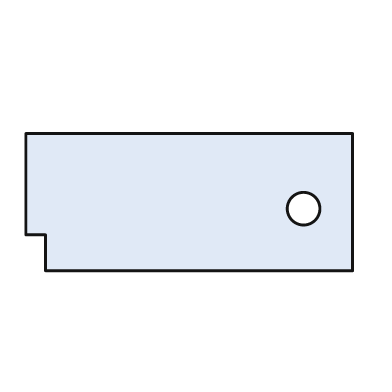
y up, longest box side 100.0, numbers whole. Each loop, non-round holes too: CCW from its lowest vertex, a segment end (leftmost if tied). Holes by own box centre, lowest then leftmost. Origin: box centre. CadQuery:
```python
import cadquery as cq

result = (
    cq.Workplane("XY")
    .moveTo(-44.0, -21.0)
    .lineTo(50.0, -21.0)
    .lineTo(50.0, 21.0)
    .lineTo(-50.0, 21.0)
    .lineTo(-50.0, -10.0)
    .lineTo(-44.0, -10.0)
    .close()
    .moveTo(35.0, -2.0)
    .circle(5.0)
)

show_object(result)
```